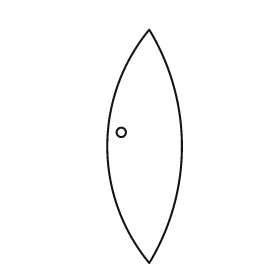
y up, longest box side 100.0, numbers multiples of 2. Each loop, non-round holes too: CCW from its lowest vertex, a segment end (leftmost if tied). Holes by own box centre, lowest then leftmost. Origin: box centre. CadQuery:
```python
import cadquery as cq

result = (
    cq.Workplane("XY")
    .moveTo(2.0, -50.0)
    .threePointArc((16.0, 0.0), (2.0, 50.0))
    .threePointArc((-16.0, 0.0), (2.0, -50.0))
    .close()
    .moveTo(-10.0, 6.0)
    .circle(2.0)
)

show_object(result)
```